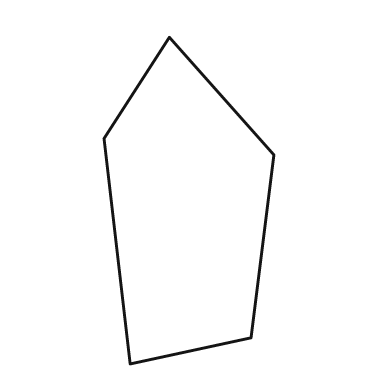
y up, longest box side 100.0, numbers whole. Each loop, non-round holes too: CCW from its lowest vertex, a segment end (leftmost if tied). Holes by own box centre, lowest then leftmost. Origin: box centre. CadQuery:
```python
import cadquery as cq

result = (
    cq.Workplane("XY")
    .moveTo(-18.0, -50.0)
    .lineTo(19.0, -42.0)
    .lineTo(26.0, 14.0)
    .lineTo(-6.0, 50.0)
    .lineTo(-26.0, 19.0)
    .close()
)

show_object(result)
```